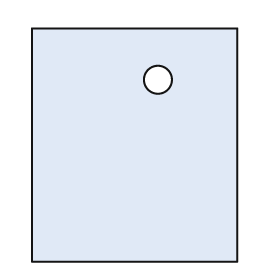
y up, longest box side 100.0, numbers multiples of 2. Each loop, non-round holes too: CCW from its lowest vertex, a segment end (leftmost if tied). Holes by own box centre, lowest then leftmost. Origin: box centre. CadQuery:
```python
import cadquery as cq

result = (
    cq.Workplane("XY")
    .moveTo(-44.0, -50.0)
    .lineTo(44.0, -50.0)
    .lineTo(44.0, 50.0)
    .lineTo(-44.0, 50.0)
    .close()
    .moveTo(10.0, 28.0)
    .circle(6.0)
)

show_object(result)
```